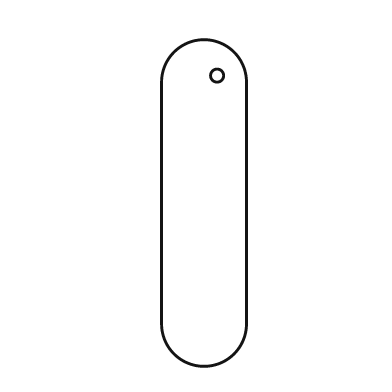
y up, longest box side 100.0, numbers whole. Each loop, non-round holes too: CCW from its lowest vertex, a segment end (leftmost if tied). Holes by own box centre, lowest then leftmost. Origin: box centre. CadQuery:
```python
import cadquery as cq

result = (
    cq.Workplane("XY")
    .moveTo(-13.0, -37.0)
    .threePointArc((0.0, -50.0), (13.0, -37.0))
    .lineTo(13.0, 37.0)
    .threePointArc((0.0, 50.0), (-13.0, 37.0))
    .close()
    .moveTo(4.0, 39.0)
    .circle(2.0)
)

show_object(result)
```